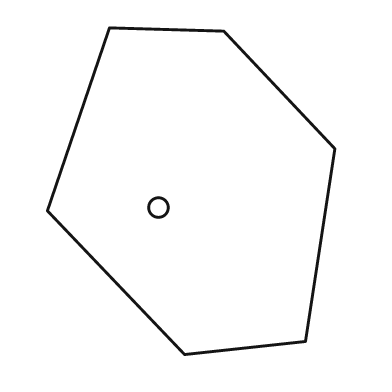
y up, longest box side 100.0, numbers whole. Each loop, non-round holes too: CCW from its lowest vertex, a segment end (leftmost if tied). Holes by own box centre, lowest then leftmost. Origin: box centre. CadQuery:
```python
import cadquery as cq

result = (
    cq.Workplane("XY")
    .moveTo(-2.0, -50.0)
    .lineTo(35.0, -46.0)
    .lineTo(44.0, 13.0)
    .lineTo(10.0, 49.0)
    .lineTo(-25.0, 50.0)
    .lineTo(-44.0, -6.0)
    .close()
    .moveTo(-10.0, -5.0)
    .circle(3.0)
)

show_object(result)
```